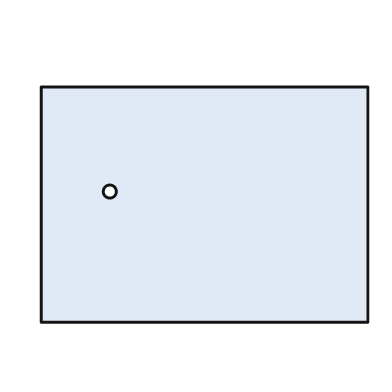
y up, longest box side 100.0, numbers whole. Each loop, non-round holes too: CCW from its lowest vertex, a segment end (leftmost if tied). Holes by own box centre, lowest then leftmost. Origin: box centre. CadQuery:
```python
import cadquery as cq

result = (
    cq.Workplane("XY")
    .moveTo(-50.0, -36.0)
    .lineTo(50.0, -36.0)
    .lineTo(50.0, 36.0)
    .lineTo(-50.0, 36.0)
    .close()
    .moveTo(-29.0, 4.0)
    .circle(2.0)
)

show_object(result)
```